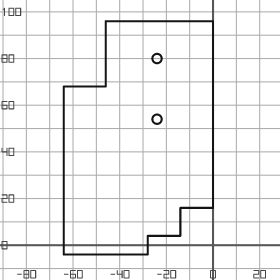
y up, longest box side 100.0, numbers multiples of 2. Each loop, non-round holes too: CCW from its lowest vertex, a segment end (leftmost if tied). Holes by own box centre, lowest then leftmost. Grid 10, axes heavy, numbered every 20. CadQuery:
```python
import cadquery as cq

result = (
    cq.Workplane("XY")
    .moveTo(-64.0, -4.0)
    .lineTo(-28.0, -4.0)
    .lineTo(-28.0, 4.0)
    .lineTo(-14.0, 4.0)
    .lineTo(-14.0, 16.0)
    .lineTo(0.0, 16.0)
    .lineTo(0.0, 96.0)
    .lineTo(-46.0, 96.0)
    .lineTo(-46.0, 68.0)
    .lineTo(-64.0, 68.0)
    .close()
    .moveTo(-24.0, 54.0)
    .circle(2.0)
    .moveTo(-24.0, 80.0)
    .circle(2.0)
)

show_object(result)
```